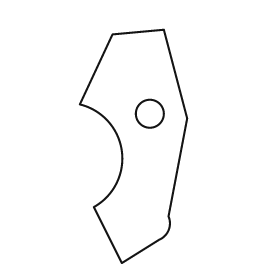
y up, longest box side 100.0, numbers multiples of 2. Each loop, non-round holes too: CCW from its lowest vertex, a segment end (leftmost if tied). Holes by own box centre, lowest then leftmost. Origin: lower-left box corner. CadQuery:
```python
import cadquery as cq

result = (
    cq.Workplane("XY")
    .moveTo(18.0, 0.0)
    .lineTo(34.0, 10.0)
    .threePointArc((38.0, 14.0), (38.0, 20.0))
    .lineTo(46.0, 62.0)
    .lineTo(36.0, 100.0)
    .lineTo(14.0, 98.0)
    .lineTo(0.0, 68.0)
    .threePointArc((18.0, 48.0), (6.0, 24.0))
    .close()
    .moveTo(30.0, 64.0)
    .circle(6.0)
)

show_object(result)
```